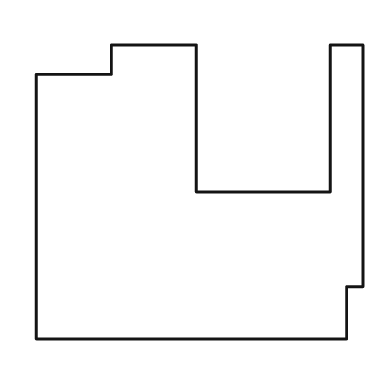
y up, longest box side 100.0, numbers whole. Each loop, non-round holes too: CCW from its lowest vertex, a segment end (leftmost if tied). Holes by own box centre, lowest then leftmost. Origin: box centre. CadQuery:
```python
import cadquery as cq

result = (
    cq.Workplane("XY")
    .moveTo(-50.0, -45.0)
    .lineTo(45.0, -45.0)
    .lineTo(45.0, -29.0)
    .lineTo(50.0, -29.0)
    .lineTo(50.0, 45.0)
    .lineTo(40.0, 45.0)
    .lineTo(40.0, 0.0)
    .lineTo(-1.0, 0.0)
    .lineTo(-1.0, 45.0)
    .lineTo(-27.0, 45.0)
    .lineTo(-27.0, 36.0)
    .lineTo(-50.0, 36.0)
    .close()
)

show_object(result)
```